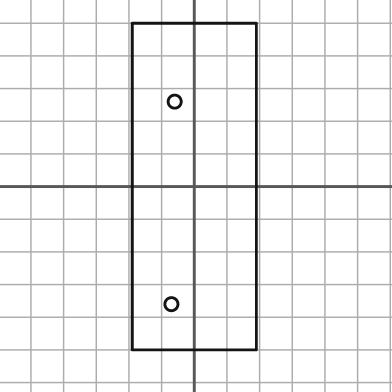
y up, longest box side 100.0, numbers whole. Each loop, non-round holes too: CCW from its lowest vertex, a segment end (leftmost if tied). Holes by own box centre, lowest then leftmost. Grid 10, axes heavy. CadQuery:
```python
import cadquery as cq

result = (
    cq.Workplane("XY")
    .moveTo(-19.0, -50.0)
    .lineTo(19.0, -50.0)
    .lineTo(19.0, 50.0)
    .lineTo(-19.0, 50.0)
    .close()
    .moveTo(-7.0, -36.0)
    .circle(2.0)
    .moveTo(-6.0, 26.0)
    .circle(2.0)
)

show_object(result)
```